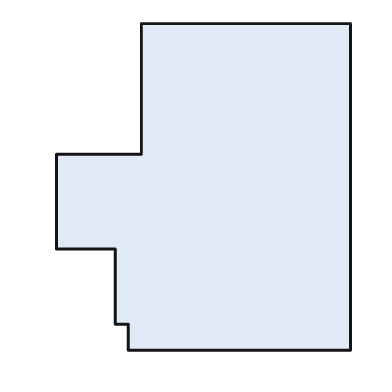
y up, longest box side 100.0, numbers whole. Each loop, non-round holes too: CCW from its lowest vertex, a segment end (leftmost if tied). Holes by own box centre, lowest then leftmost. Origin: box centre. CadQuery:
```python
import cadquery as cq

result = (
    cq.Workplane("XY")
    .moveTo(-23.0, -50.0)
    .lineTo(45.0, -50.0)
    .lineTo(45.0, 50.0)
    .lineTo(-19.0, 50.0)
    .lineTo(-19.0, 10.0)
    .lineTo(-45.0, 10.0)
    .lineTo(-45.0, -19.0)
    .lineTo(-27.0, -19.0)
    .lineTo(-27.0, -42.0)
    .lineTo(-23.0, -42.0)
    .close()
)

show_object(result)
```